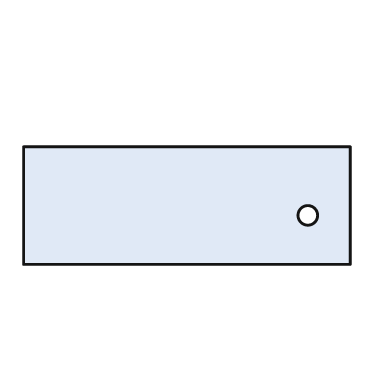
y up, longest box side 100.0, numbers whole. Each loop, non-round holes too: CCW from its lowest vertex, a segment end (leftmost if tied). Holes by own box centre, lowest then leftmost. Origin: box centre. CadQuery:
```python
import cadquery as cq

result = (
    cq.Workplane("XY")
    .moveTo(-50.0, -18.0)
    .lineTo(50.0, -18.0)
    .lineTo(50.0, 18.0)
    .lineTo(-50.0, 18.0)
    .close()
    .moveTo(37.0, -3.0)
    .circle(3.0)
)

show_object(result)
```